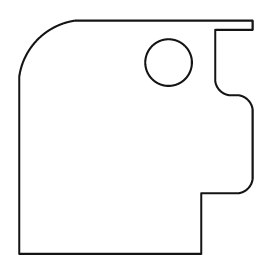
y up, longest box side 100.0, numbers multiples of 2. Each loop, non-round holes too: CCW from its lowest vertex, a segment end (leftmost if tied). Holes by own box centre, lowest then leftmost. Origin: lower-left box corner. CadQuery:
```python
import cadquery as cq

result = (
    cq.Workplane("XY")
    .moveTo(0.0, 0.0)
    .lineTo(78.0, 0.0)
    .lineTo(78.0, 26.0)
    .lineTo(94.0, 26.0)
    .threePointArc((98.0, 28.0), (100.0, 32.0))
    .lineTo(100.0, 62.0)
    .threePointArc((98.0, 66.0), (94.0, 68.0))
    .lineTo(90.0, 68.0)
    .threePointArc((86.0, 70.0), (84.0, 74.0))
    .lineTo(84.0, 96.0)
    .lineTo(100.0, 96.0)
    .lineTo(100.0, 100.0)
    .lineTo(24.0, 100.0)
    .threePointArc((8.0, 92.0), (0.0, 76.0))
    .close()
    .moveTo(64.0, 82.0)
    .circle(10.0)
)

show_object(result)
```